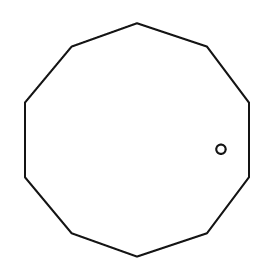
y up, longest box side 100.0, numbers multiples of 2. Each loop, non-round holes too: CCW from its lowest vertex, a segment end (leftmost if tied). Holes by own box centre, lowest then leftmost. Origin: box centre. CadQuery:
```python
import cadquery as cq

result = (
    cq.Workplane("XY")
    .moveTo(0.0, -50.0)
    .lineTo(30.0, -40.0)
    .lineTo(48.0, -16.0)
    .lineTo(48.0, 16.0)
    .lineTo(30.0, 40.0)
    .lineTo(0.0, 50.0)
    .lineTo(-28.0, 40.0)
    .lineTo(-48.0, 16.0)
    .lineTo(-48.0, -16.0)
    .lineTo(-28.0, -40.0)
    .close()
    .moveTo(36.0, -4.0)
    .circle(2.0)
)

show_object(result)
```